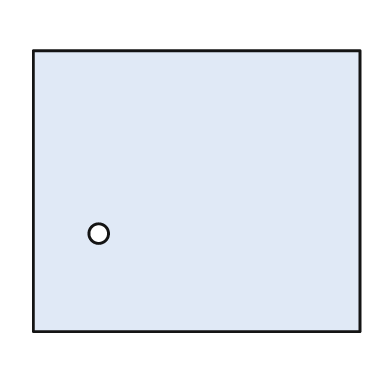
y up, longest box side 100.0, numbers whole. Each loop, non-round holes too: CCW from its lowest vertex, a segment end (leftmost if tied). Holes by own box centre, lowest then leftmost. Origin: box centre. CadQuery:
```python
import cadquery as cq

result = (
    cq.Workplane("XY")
    .moveTo(-50.0, -43.0)
    .lineTo(50.0, -43.0)
    .lineTo(50.0, 43.0)
    .lineTo(-50.0, 43.0)
    .close()
    .moveTo(-30.0, -13.0)
    .circle(3.0)
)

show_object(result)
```